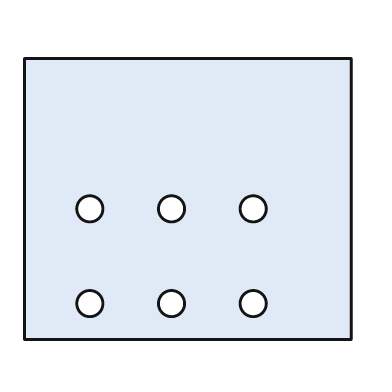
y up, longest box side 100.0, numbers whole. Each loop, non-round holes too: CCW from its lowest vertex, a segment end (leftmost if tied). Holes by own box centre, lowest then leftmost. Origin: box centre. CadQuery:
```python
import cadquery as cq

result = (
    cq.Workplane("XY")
    .moveTo(-50.0, -43.0)
    .lineTo(50.0, -43.0)
    .lineTo(50.0, 43.0)
    .lineTo(-50.0, 43.0)
    .close()
    .moveTo(-30.0, -32.0)
    .circle(4.0)
    .moveTo(-5.0, -32.0)
    .circle(4.0)
    .moveTo(20.0, -32.0)
    .circle(4.0)
    .moveTo(-30.0, -3.0)
    .circle(4.0)
    .moveTo(-5.0, -3.0)
    .circle(4.0)
    .moveTo(20.0, -3.0)
    .circle(4.0)
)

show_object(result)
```